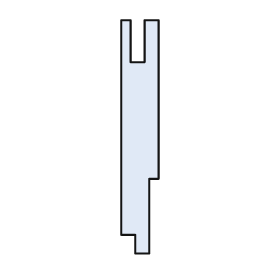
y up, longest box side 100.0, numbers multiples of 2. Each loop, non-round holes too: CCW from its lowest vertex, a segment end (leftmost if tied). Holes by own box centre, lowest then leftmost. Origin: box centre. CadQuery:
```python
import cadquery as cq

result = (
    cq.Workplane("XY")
    .moveTo(-2.0, -50.0)
    .lineTo(4.0, -50.0)
    .lineTo(4.0, -18.0)
    .lineTo(8.0, -18.0)
    .lineTo(8.0, 50.0)
    .lineTo(2.0, 50.0)
    .lineTo(2.0, 32.0)
    .lineTo(-4.0, 32.0)
    .lineTo(-4.0, 50.0)
    .lineTo(-8.0, 50.0)
    .lineTo(-8.0, -42.0)
    .lineTo(-2.0, -42.0)
    .close()
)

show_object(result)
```